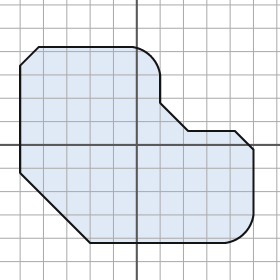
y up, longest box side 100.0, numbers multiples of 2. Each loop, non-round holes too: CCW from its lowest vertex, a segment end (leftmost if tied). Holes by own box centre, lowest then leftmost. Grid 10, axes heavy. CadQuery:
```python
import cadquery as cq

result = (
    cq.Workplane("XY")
    .moveTo(-20.0, -42.0)
    .lineTo(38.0, -42.0)
    .threePointArc((46.0, -38.0), (50.0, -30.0))
    .lineTo(50.0, -2.0)
    .lineTo(42.0, 6.0)
    .lineTo(22.0, 6.0)
    .lineTo(10.0, 18.0)
    .lineTo(10.0, 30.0)
    .threePointArc((6.0, 38.0), (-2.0, 42.0))
    .lineTo(-42.0, 42.0)
    .lineTo(-50.0, 34.0)
    .lineTo(-50.0, -12.0)
    .close()
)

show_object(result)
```